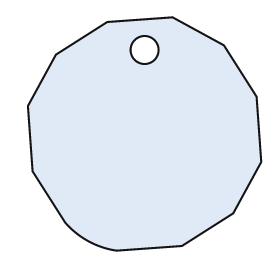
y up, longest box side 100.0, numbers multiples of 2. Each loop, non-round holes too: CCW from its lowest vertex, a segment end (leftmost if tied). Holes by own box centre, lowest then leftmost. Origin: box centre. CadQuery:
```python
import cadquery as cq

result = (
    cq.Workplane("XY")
    .moveTo(-12.0, -50.0)
    .lineTo(16.0, -48.0)
    .lineTo(38.0, -34.0)
    .lineTo(50.0, -12.0)
    .lineTo(48.0, 16.0)
    .lineTo(34.0, 38.0)
    .lineTo(12.0, 50.0)
    .lineTo(-16.0, 48.0)
    .lineTo(-38.0, 34.0)
    .lineTo(-50.0, 12.0)
    .lineTo(-48.0, -16.0)
    .lineTo(-34.0, -38.0)
    .threePointArc((-24.0, -46.0), (-12.0, -50.0))
    .close()
    .moveTo(0.0, 36.0)
    .circle(6.0)
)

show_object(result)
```